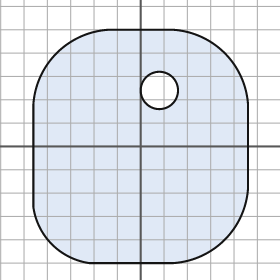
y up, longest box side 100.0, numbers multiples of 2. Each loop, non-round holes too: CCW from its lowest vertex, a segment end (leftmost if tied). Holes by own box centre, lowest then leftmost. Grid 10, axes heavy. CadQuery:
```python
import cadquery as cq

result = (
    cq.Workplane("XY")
    .moveTo(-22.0, -50.0)
    .lineTo(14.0, -50.0)
    .threePointArc((36.0, -40.0), (46.0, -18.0))
    .lineTo(46.0, 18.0)
    .threePointArc((36.0, 40.0), (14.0, 50.0))
    .lineTo(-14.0, 50.0)
    .threePointArc((-36.0, 40.0), (-46.0, 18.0))
    .lineTo(-46.0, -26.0)
    .threePointArc((-38.0, -42.0), (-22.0, -50.0))
    .close()
    .moveTo(8.0, 24.0)
    .circle(8.0)
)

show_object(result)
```